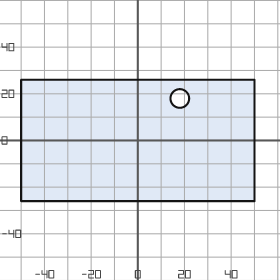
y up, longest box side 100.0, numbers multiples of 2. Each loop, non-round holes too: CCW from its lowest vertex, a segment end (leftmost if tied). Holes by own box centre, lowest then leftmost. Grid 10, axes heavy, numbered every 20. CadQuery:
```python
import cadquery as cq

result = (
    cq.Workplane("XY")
    .moveTo(-50.0, -26.0)
    .lineTo(50.0, -26.0)
    .lineTo(50.0, 26.0)
    .lineTo(-50.0, 26.0)
    .close()
    .moveTo(18.0, 18.0)
    .circle(4.0)
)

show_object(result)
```